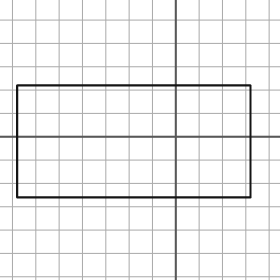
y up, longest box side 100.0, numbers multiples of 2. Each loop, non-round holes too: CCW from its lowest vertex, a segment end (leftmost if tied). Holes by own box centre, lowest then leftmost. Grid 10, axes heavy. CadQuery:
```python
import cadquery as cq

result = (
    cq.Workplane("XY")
    .moveTo(-68.0, -26.0)
    .lineTo(32.0, -26.0)
    .lineTo(32.0, 22.0)
    .lineTo(-68.0, 22.0)
    .close()
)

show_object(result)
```